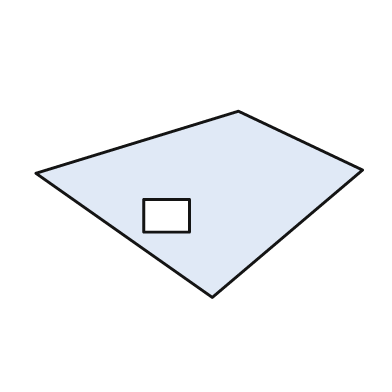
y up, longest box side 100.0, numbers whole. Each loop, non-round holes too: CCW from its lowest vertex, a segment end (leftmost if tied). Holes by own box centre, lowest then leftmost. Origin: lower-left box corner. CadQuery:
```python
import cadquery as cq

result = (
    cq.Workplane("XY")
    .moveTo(54.0, 0.0)
    .lineTo(100.0, 39.0)
    .lineTo(62.0, 57.0)
    .lineTo(0.0, 38.0)
    .close()
    .moveTo(33.0, 20.0)
    .lineTo(47.0, 20.0)
    .lineTo(47.0, 30.0)
    .lineTo(33.0, 30.0)
    .close()
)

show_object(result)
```